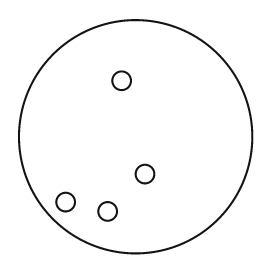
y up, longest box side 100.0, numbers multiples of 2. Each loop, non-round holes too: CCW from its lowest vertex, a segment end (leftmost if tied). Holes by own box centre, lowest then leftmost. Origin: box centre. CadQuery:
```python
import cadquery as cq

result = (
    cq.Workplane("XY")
    .moveTo(0.0, 0.0)
    .circle(50.0)
    .moveTo(-12.0, -32.0)
    .circle(4.0)
    .moveTo(-30.0, -28.0)
    .circle(4.0)
    .moveTo(4.0, -16.0)
    .circle(4.0)
    .moveTo(-6.0, 24.0)
    .circle(4.0)
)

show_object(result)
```